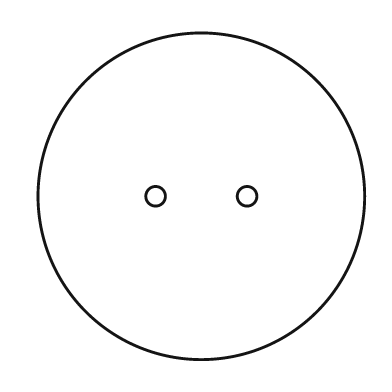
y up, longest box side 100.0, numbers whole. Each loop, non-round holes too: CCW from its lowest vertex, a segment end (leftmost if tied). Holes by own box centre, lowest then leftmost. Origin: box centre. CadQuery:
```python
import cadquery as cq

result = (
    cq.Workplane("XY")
    .moveTo(0.0, 0.0)
    .circle(50.0)
    .moveTo(-14.0, 0.0)
    .circle(3.0)
    .moveTo(14.0, 0.0)
    .circle(3.0)
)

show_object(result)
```